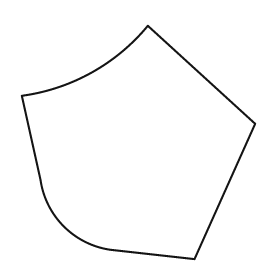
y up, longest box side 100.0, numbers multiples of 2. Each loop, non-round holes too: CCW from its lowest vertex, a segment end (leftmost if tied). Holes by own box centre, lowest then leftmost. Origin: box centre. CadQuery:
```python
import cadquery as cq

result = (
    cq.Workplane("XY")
    .moveTo(24.0, -50.0)
    .lineTo(50.0, 8.0)
    .lineTo(4.0, 50.0)
    .threePointArc((-20.0, 30.0), (-50.0, 20.0))
    .lineTo(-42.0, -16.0)
    .threePointArc((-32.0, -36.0), (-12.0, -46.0))
    .close()
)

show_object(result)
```